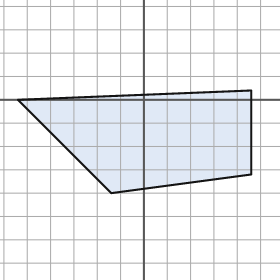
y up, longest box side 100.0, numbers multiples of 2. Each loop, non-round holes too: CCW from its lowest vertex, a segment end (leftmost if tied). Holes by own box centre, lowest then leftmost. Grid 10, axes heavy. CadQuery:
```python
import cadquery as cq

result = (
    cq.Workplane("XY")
    .moveTo(-14.0, -40.0)
    .lineTo(46.0, -32.0)
    .lineTo(46.0, 4.0)
    .lineTo(-54.0, 0.0)
    .close()
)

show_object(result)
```